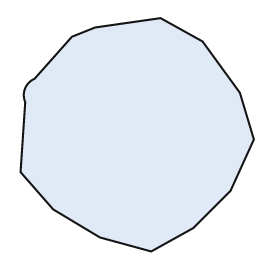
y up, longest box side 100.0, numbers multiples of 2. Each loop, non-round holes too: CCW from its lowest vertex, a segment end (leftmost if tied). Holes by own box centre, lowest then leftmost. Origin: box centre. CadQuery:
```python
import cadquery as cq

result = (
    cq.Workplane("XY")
    .moveTo(6.0, -50.0)
    .lineTo(24.0, -40.0)
    .lineTo(40.0, -24.0)
    .lineTo(50.0, -2.0)
    .lineTo(44.0, 18.0)
    .lineTo(28.0, 40.0)
    .lineTo(10.0, 50.0)
    .lineTo(-18.0, 46.0)
    .lineTo(-28.0, 42.0)
    .lineTo(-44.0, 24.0)
    .threePointArc((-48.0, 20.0), (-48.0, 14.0))
    .lineTo(-50.0, -16.0)
    .lineTo(-36.0, -32.0)
    .lineTo(-16.0, -44.0)
    .close()
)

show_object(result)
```